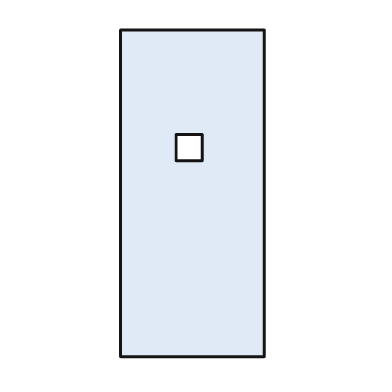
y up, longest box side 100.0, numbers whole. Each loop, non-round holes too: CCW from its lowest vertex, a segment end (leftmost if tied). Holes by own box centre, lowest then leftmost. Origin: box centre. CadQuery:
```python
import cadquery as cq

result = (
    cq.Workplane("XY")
    .moveTo(-22.0, -50.0)
    .lineTo(22.0, -50.0)
    .lineTo(22.0, 50.0)
    .lineTo(-22.0, 50.0)
    .close()
    .moveTo(-5.0, 10.0)
    .lineTo(3.0, 10.0)
    .lineTo(3.0, 18.0)
    .lineTo(-5.0, 18.0)
    .close()
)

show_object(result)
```